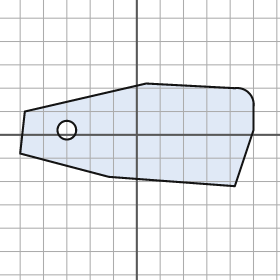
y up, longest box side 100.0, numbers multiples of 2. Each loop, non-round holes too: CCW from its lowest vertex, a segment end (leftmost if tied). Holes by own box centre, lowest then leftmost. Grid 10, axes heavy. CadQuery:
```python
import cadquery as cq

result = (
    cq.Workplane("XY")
    .moveTo(42.0, -22.0)
    .lineTo(50.0, 2.0)
    .lineTo(50.0, 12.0)
    .threePointArc((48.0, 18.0), (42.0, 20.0))
    .lineTo(4.0, 22.0)
    .lineTo(-48.0, 10.0)
    .lineTo(-50.0, -8.0)
    .lineTo(-12.0, -18.0)
    .close()
    .moveTo(-30.0, 2.0)
    .circle(4.0)
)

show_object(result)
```